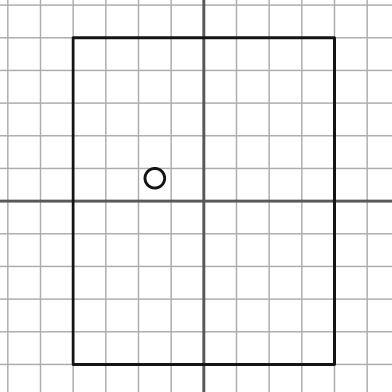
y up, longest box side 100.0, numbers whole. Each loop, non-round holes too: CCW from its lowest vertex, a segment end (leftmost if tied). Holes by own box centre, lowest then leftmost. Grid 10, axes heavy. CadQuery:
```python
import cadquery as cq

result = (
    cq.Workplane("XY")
    .moveTo(-40.0, -50.0)
    .lineTo(40.0, -50.0)
    .lineTo(40.0, 50.0)
    .lineTo(-40.0, 50.0)
    .close()
    .moveTo(-15.0, 7.0)
    .circle(3.0)
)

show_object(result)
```